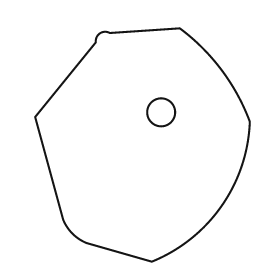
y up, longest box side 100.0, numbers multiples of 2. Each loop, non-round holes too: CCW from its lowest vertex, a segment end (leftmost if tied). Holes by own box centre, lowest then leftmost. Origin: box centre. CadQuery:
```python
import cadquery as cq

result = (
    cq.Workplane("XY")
    .moveTo(4.0, -50.0)
    .threePointArc((34.0, -26.0), (46.0, 10.0))
    .threePointArc((34.0, 32.0), (16.0, 50.0))
    .lineTo(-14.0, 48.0)
    .threePointArc((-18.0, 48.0), (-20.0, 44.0))
    .lineTo(-46.0, 12.0)
    .lineTo(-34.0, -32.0)
    .threePointArc((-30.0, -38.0), (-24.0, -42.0))
    .close()
    .moveTo(8.0, 14.0)
    .circle(6.0)
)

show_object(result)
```